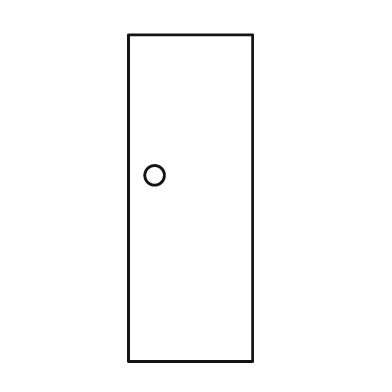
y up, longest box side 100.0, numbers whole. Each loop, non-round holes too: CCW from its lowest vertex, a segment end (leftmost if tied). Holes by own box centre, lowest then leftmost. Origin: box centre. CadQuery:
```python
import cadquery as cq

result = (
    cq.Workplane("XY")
    .moveTo(-19.0, -50.0)
    .lineTo(19.0, -50.0)
    .lineTo(19.0, 50.0)
    .lineTo(-19.0, 50.0)
    .close()
    .moveTo(-11.0, 7.0)
    .circle(3.0)
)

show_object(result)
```